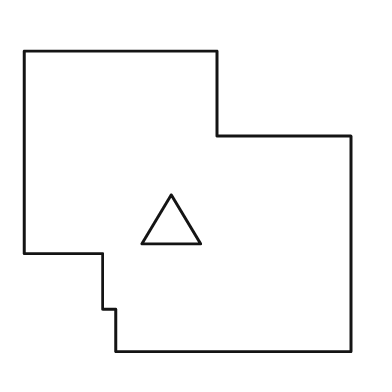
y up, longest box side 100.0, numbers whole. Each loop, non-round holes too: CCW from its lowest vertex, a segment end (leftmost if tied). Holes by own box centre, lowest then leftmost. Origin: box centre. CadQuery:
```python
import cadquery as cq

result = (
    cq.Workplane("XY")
    .moveTo(-22.0, -46.0)
    .lineTo(50.0, -46.0)
    .lineTo(50.0, 20.0)
    .lineTo(9.0, 20.0)
    .lineTo(9.0, 46.0)
    .lineTo(-50.0, 46.0)
    .lineTo(-50.0, -16.0)
    .lineTo(-26.0, -16.0)
    .lineTo(-26.0, -33.0)
    .lineTo(-22.0, -33.0)
    .close()
    .moveTo(-14.0, -13.0)
    .lineTo(4.0, -13.0)
    .lineTo(-5.0, 2.0)
    .close()
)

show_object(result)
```